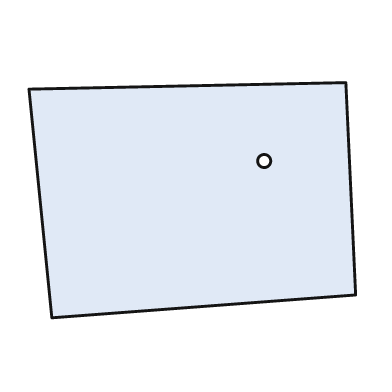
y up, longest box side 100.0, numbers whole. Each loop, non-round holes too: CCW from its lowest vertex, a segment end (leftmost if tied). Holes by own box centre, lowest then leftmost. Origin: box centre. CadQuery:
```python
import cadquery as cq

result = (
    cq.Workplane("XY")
    .moveTo(-43.0, -36.0)
    .lineTo(50.0, -29.0)
    .lineTo(47.0, 36.0)
    .lineTo(-50.0, 34.0)
    .close()
    .moveTo(22.0, 12.0)
    .circle(2.0)
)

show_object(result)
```